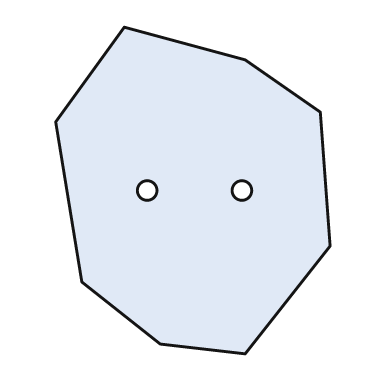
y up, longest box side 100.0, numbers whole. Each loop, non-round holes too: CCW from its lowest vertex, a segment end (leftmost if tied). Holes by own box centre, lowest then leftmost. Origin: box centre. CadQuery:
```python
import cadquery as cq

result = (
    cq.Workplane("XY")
    .moveTo(16.0, -50.0)
    .lineTo(42.0, -17.0)
    .lineTo(39.0, 24.0)
    .lineTo(16.0, 40.0)
    .lineTo(-21.0, 50.0)
    .lineTo(-42.0, 21.0)
    .lineTo(-34.0, -28.0)
    .lineTo(-10.0, -47.0)
    .close()
    .moveTo(-14.0, 0.0)
    .circle(3.0)
    .moveTo(15.0, 0.0)
    .circle(3.0)
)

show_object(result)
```